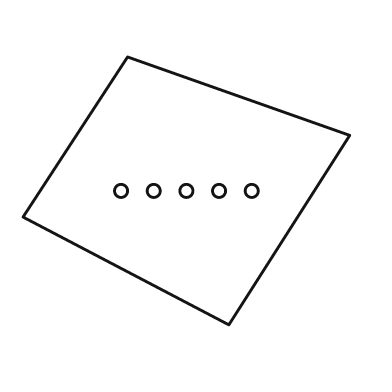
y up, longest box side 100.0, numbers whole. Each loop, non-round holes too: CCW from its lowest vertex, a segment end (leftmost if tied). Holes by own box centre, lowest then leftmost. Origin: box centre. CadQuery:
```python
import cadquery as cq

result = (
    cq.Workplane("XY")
    .moveTo(13.0, -41.0)
    .lineTo(50.0, 17.0)
    .lineTo(-18.0, 41.0)
    .lineTo(-50.0, -8.0)
    .close()
    .moveTo(-20.0, 0.0)
    .circle(2.0)
    .moveTo(-10.0, 0.0)
    .circle(2.0)
    .moveTo(0.0, 0.0)
    .circle(2.0)
    .moveTo(10.0, 0.0)
    .circle(2.0)
    .moveTo(20.0, 0.0)
    .circle(2.0)
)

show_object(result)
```